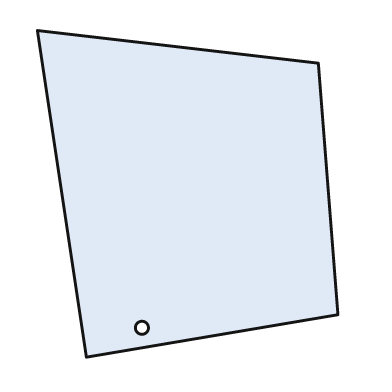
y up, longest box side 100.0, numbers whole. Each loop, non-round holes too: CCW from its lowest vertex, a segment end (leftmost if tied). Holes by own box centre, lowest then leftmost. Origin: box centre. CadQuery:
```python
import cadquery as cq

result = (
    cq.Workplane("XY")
    .moveTo(-31.0, -50.0)
    .lineTo(46.0, -37.0)
    .lineTo(40.0, 40.0)
    .lineTo(-46.0, 50.0)
    .close()
    .moveTo(-14.0, -41.0)
    .circle(2.0)
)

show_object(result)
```